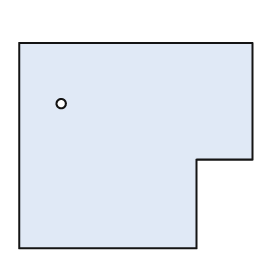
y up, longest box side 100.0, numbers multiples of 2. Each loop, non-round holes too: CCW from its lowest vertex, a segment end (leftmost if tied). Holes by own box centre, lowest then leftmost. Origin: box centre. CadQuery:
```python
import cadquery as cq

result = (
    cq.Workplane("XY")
    .moveTo(-50.0, -44.0)
    .lineTo(26.0, -44.0)
    .lineTo(26.0, -6.0)
    .lineTo(50.0, -6.0)
    .lineTo(50.0, 44.0)
    .lineTo(-50.0, 44.0)
    .close()
    .moveTo(-32.0, 18.0)
    .circle(2.0)
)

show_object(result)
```